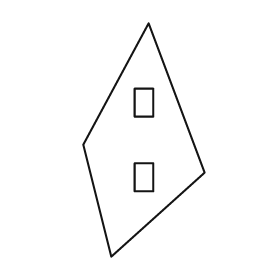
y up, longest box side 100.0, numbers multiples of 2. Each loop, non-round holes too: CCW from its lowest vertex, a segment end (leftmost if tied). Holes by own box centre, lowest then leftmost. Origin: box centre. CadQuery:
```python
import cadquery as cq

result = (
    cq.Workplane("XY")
    .moveTo(-14.0, -50.0)
    .lineTo(26.0, -14.0)
    .lineTo(2.0, 50.0)
    .lineTo(-26.0, -2.0)
    .close()
    .moveTo(-4.0, -22.0)
    .lineTo(4.0, -22.0)
    .lineTo(4.0, -10.0)
    .lineTo(-4.0, -10.0)
    .close()
    .moveTo(-4.0, 10.0)
    .lineTo(4.0, 10.0)
    .lineTo(4.0, 22.0)
    .lineTo(-4.0, 22.0)
    .close()
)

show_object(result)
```